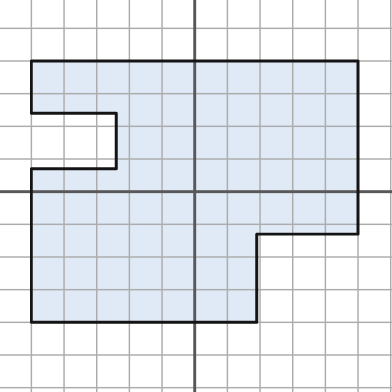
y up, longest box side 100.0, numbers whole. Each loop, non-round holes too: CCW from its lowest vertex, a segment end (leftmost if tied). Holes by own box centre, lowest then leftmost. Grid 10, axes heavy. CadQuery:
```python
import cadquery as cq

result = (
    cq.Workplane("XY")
    .moveTo(-50.0, -40.0)
    .lineTo(19.0, -40.0)
    .lineTo(19.0, -13.0)
    .lineTo(50.0, -13.0)
    .lineTo(50.0, 40.0)
    .lineTo(-50.0, 40.0)
    .lineTo(-50.0, 24.0)
    .lineTo(-24.0, 24.0)
    .lineTo(-24.0, 7.0)
    .lineTo(-50.0, 7.0)
    .close()
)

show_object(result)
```